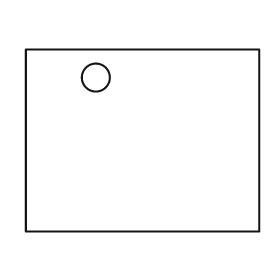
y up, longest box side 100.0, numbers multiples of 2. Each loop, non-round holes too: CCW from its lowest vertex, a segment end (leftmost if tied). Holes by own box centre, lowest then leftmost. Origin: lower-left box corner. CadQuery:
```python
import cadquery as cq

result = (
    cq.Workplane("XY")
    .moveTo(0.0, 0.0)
    .lineTo(100.0, 0.0)
    .lineTo(100.0, 78.0)
    .lineTo(0.0, 78.0)
    .close()
    .moveTo(30.0, 66.0)
    .circle(6.0)
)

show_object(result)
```